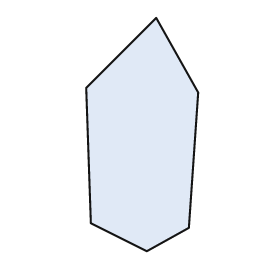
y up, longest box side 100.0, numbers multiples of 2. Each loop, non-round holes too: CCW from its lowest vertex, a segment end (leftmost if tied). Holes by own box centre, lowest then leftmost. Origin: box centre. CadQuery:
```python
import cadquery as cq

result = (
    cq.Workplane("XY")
    .moveTo(2.0, -50.0)
    .lineTo(20.0, -40.0)
    .lineTo(24.0, 18.0)
    .lineTo(6.0, 50.0)
    .lineTo(-24.0, 20.0)
    .lineTo(-22.0, -38.0)
    .close()
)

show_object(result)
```